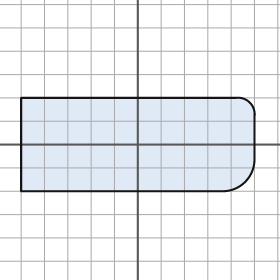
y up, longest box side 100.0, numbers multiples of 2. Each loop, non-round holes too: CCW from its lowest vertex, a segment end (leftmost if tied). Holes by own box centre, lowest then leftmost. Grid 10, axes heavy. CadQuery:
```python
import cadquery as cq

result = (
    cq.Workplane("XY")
    .moveTo(-50.0, -20.0)
    .lineTo(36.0, -20.0)
    .threePointArc((46.0, -16.0), (50.0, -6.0))
    .lineTo(50.0, 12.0)
    .threePointArc((48.0, 18.0), (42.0, 20.0))
    .lineTo(-50.0, 20.0)
    .close()
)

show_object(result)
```